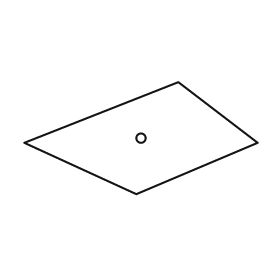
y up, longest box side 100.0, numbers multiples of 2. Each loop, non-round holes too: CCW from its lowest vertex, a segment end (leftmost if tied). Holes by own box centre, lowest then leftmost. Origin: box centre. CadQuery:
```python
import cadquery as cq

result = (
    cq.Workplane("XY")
    .moveTo(-2.0, -24.0)
    .lineTo(50.0, -2.0)
    .lineTo(16.0, 24.0)
    .lineTo(-50.0, -2.0)
    .close()
    .moveTo(0.0, 0.0)
    .circle(2.0)
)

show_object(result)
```